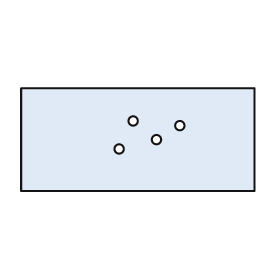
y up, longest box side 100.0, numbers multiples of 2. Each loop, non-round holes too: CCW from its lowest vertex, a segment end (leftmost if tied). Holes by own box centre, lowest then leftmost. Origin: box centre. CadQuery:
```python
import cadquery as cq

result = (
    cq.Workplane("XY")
    .moveTo(-50.0, -22.0)
    .lineTo(50.0, -22.0)
    .lineTo(50.0, 22.0)
    .lineTo(-50.0, 22.0)
    .close()
    .moveTo(-8.0, -4.0)
    .circle(2.0)
    .moveTo(8.0, 0.0)
    .circle(2.0)
    .moveTo(18.0, 6.0)
    .circle(2.0)
    .moveTo(-2.0, 8.0)
    .circle(2.0)
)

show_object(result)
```